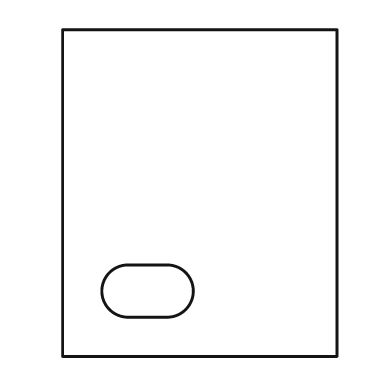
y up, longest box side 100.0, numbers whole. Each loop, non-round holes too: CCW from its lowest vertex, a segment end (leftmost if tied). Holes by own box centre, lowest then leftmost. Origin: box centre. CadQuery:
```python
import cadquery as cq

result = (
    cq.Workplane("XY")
    .moveTo(-42.0, -50.0)
    .lineTo(42.0, -50.0)
    .lineTo(42.0, 50.0)
    .lineTo(-42.0, 50.0)
    .close()
    .moveTo(-22.0, -38.0)
    .lineTo(-10.0, -38.0)
    .threePointArc((-2.0, -30.0), (-10.0, -22.0))
    .lineTo(-22.0, -22.0)
    .threePointArc((-30.0, -30.0), (-22.0, -38.0))
    .close()
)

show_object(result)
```